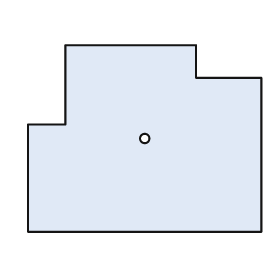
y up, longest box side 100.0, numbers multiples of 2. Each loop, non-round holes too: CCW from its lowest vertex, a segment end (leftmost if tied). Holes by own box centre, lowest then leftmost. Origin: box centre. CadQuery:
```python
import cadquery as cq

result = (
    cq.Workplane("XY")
    .moveTo(-50.0, -40.0)
    .lineTo(50.0, -40.0)
    .lineTo(50.0, 26.0)
    .lineTo(22.0, 26.0)
    .lineTo(22.0, 40.0)
    .lineTo(-34.0, 40.0)
    .lineTo(-34.0, 6.0)
    .lineTo(-50.0, 6.0)
    .close()
    .moveTo(0.0, 0.0)
    .circle(2.0)
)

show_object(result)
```